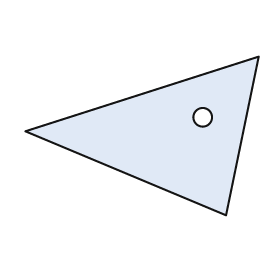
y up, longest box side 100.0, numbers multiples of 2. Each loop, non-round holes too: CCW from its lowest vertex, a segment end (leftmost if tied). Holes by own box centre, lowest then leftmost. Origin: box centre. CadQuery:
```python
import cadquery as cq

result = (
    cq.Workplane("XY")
    .moveTo(36.0, -34.0)
    .lineTo(50.0, 34.0)
    .lineTo(-50.0, 2.0)
    .close()
    .moveTo(26.0, 8.0)
    .circle(4.0)
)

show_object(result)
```